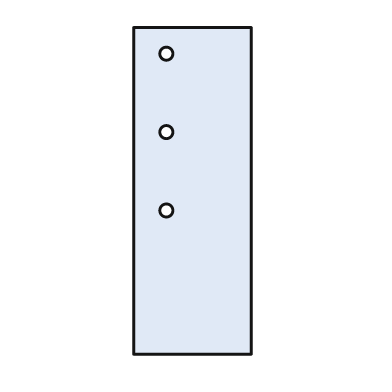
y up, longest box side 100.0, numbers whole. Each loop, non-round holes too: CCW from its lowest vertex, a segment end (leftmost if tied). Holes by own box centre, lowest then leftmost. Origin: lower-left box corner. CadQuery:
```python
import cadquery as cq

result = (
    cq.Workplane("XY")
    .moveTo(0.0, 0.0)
    .lineTo(36.0, 0.0)
    .lineTo(36.0, 100.0)
    .lineTo(0.0, 100.0)
    .close()
    .moveTo(10.0, 44.0)
    .circle(2.0)
    .moveTo(10.0, 68.0)
    .circle(2.0)
    .moveTo(10.0, 92.0)
    .circle(2.0)
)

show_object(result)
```